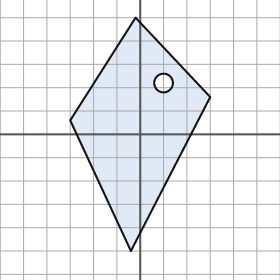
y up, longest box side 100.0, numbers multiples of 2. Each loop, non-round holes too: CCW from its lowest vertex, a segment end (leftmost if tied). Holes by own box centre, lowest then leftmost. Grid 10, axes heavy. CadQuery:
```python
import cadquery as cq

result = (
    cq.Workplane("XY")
    .moveTo(-4.0, -50.0)
    .lineTo(30.0, 16.0)
    .lineTo(-2.0, 50.0)
    .lineTo(-30.0, 6.0)
    .close()
    .moveTo(10.0, 22.0)
    .circle(4.0)
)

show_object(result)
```